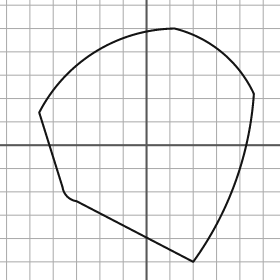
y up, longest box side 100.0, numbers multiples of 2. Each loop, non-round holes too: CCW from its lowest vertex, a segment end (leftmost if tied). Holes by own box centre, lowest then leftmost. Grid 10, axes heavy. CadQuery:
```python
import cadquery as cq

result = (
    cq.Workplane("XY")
    .moveTo(20.0, -50.0)
    .threePointArc((38.0, -16.0), (46.0, 22.0))
    .threePointArc((32.0, 40.0), (12.0, 50.0))
    .threePointArc((-22.0, 40.0), (-46.0, 14.0))
    .lineTo(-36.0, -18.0)
    .threePointArc((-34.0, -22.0), (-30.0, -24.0))
    .close()
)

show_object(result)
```